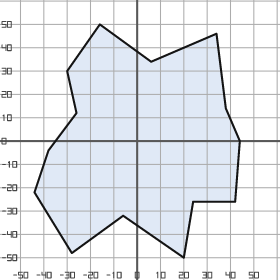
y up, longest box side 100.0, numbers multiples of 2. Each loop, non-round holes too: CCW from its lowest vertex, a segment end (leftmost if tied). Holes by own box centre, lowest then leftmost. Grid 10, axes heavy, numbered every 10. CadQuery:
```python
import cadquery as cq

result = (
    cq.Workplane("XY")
    .moveTo(20.0, -50.0)
    .lineTo(24.0, -26.0)
    .lineTo(42.0, -26.0)
    .lineTo(44.0, 0.0)
    .lineTo(38.0, 14.0)
    .lineTo(34.0, 46.0)
    .lineTo(6.0, 34.0)
    .lineTo(-16.0, 50.0)
    .lineTo(-30.0, 30.0)
    .lineTo(-26.0, 12.0)
    .lineTo(-38.0, -4.0)
    .lineTo(-44.0, -22.0)
    .lineTo(-28.0, -48.0)
    .lineTo(-6.0, -32.0)
    .close()
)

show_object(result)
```